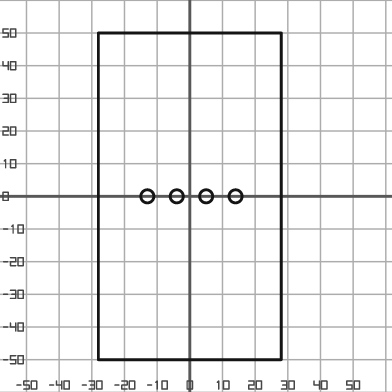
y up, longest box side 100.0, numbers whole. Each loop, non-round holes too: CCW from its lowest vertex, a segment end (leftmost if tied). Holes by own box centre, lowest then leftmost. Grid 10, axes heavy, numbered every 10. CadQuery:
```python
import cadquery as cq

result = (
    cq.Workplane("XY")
    .moveTo(-28.0, -50.0)
    .lineTo(28.0, -50.0)
    .lineTo(28.0, 50.0)
    .lineTo(-28.0, 50.0)
    .close()
    .moveTo(-13.0, 0.0)
    .circle(2.0)
    .moveTo(-4.0, 0.0)
    .circle(2.0)
    .moveTo(5.0, 0.0)
    .circle(2.0)
    .moveTo(14.0, 0.0)
    .circle(2.0)
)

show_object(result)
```